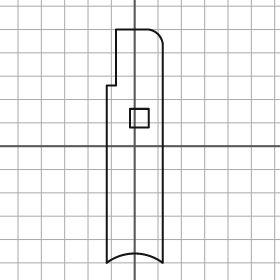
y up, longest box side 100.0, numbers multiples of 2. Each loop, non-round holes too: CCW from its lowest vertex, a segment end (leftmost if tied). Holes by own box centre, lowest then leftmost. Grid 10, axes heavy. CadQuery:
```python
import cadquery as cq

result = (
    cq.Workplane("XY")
    .moveTo(-12.0, -50.0)
    .threePointArc((0.0, -46.0), (12.0, -50.0))
    .lineTo(12.0, 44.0)
    .threePointArc((10.0, 48.0), (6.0, 50.0))
    .lineTo(-8.0, 50.0)
    .lineTo(-8.0, 26.0)
    .lineTo(-12.0, 26.0)
    .close()
    .moveTo(-2.0, 8.0)
    .lineTo(6.0, 8.0)
    .lineTo(6.0, 16.0)
    .lineTo(-2.0, 16.0)
    .close()
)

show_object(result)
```